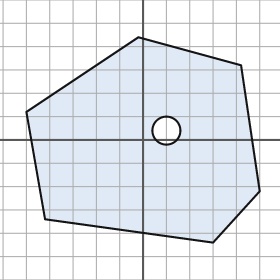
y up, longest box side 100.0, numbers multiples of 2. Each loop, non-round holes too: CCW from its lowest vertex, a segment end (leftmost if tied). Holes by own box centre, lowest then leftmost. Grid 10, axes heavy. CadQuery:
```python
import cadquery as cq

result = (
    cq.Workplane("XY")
    .moveTo(30.0, -44.0)
    .lineTo(50.0, -22.0)
    .lineTo(42.0, 32.0)
    .lineTo(-2.0, 44.0)
    .lineTo(-50.0, 12.0)
    .lineTo(-42.0, -34.0)
    .close()
    .moveTo(10.0, 4.0)
    .circle(6.0)
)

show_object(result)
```